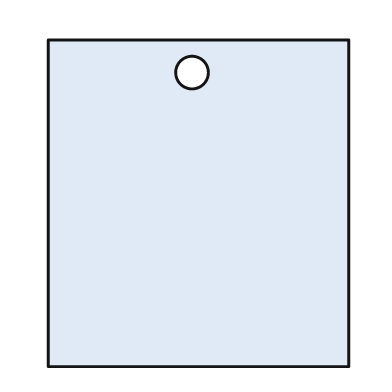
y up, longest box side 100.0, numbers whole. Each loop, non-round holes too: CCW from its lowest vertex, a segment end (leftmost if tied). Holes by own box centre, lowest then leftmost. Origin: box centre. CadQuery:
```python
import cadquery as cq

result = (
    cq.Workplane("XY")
    .moveTo(-46.0, -50.0)
    .lineTo(46.0, -50.0)
    .lineTo(46.0, 50.0)
    .lineTo(-46.0, 50.0)
    .close()
    .moveTo(-2.0, 40.0)
    .circle(5.0)
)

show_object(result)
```